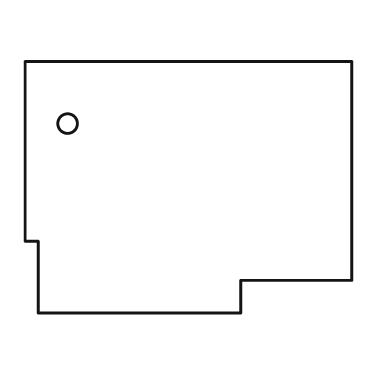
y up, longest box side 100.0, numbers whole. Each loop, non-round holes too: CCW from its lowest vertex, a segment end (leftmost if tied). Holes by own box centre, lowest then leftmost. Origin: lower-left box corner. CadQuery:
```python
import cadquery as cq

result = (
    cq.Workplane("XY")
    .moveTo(4.0, 0.0)
    .lineTo(66.0, 0.0)
    .lineTo(66.0, 10.0)
    .lineTo(100.0, 10.0)
    .lineTo(100.0, 77.0)
    .lineTo(0.0, 77.0)
    .lineTo(0.0, 22.0)
    .lineTo(4.0, 22.0)
    .close()
    .moveTo(13.0, 58.0)
    .circle(3.0)
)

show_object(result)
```